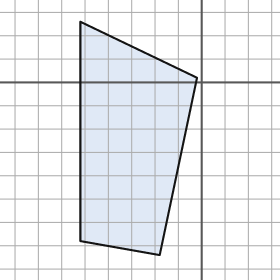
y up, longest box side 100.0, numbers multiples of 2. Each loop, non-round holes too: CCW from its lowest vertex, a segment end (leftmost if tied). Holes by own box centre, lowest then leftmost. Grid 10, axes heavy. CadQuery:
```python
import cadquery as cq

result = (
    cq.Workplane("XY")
    .moveTo(-18.0, -74.0)
    .lineTo(-2.0, 2.0)
    .lineTo(-52.0, 26.0)
    .lineTo(-52.0, -68.0)
    .close()
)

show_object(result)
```